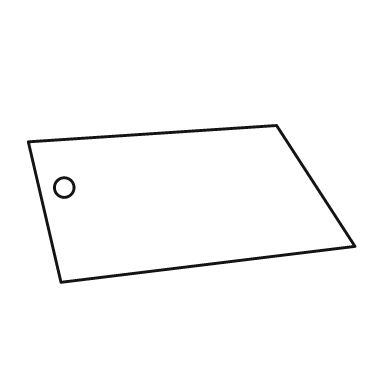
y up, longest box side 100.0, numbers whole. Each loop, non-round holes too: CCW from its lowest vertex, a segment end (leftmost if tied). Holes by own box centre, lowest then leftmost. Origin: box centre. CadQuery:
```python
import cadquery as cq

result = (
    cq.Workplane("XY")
    .moveTo(-40.0, -24.0)
    .lineTo(50.0, -13.0)
    .lineTo(26.0, 24.0)
    .lineTo(-50.0, 19.0)
    .close()
    .moveTo(-39.0, 5.0)
    .circle(3.0)
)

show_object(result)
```